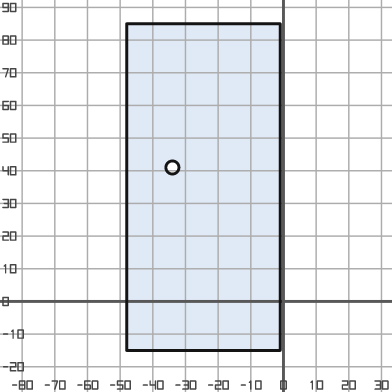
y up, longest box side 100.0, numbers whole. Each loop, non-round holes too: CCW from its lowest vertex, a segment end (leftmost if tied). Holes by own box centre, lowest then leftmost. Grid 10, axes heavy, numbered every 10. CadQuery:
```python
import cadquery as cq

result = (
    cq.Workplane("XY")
    .moveTo(-48.0, -15.0)
    .lineTo(-1.0, -15.0)
    .lineTo(-1.0, 85.0)
    .lineTo(-48.0, 85.0)
    .close()
    .moveTo(-34.0, 41.0)
    .circle(2.0)
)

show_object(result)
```